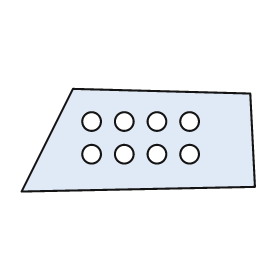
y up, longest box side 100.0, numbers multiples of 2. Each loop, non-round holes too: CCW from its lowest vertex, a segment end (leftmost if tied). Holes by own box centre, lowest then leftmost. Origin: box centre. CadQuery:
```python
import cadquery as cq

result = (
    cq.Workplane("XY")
    .moveTo(-50.0, -22.0)
    .lineTo(50.0, -20.0)
    .lineTo(48.0, 20.0)
    .lineTo(-28.0, 22.0)
    .close()
    .moveTo(-20.0, -6.0)
    .circle(4.0)
    .moveTo(-6.0, -6.0)
    .circle(4.0)
    .moveTo(8.0, -6.0)
    .circle(4.0)
    .moveTo(22.0, -6.0)
    .circle(4.0)
    .moveTo(-20.0, 8.0)
    .circle(4.0)
    .moveTo(-6.0, 8.0)
    .circle(4.0)
    .moveTo(8.0, 8.0)
    .circle(4.0)
    .moveTo(22.0, 8.0)
    .circle(4.0)
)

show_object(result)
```